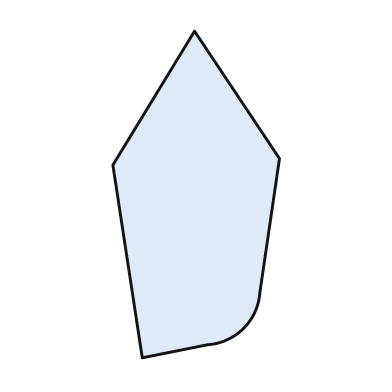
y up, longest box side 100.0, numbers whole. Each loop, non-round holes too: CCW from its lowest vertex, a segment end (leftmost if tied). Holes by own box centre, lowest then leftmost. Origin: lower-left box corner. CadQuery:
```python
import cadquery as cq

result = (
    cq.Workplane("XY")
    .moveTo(9.0, 0.0)
    .lineTo(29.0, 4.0)
    .threePointArc((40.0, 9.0), (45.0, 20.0))
    .lineTo(51.0, 61.0)
    .lineTo(25.0, 100.0)
    .lineTo(0.0, 59.0)
    .close()
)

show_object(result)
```